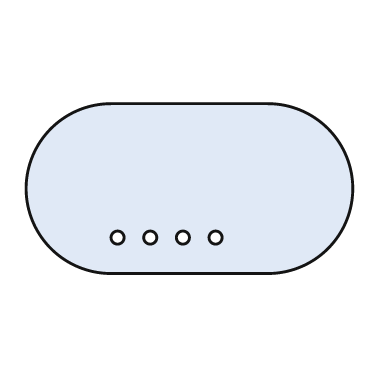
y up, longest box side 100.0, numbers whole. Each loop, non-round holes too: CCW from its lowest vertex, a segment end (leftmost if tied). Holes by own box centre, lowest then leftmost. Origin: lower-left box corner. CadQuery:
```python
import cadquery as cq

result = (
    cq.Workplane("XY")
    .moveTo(26.0, 0.0)
    .lineTo(74.0, 0.0)
    .threePointArc((100.0, 26.0), (74.0, 52.0))
    .lineTo(26.0, 52.0)
    .threePointArc((0.0, 26.0), (26.0, 0.0))
    .close()
    .moveTo(28.0, 11.0)
    .circle(2.0)
    .moveTo(38.0, 11.0)
    .circle(2.0)
    .moveTo(48.0, 11.0)
    .circle(2.0)
    .moveTo(58.0, 11.0)
    .circle(2.0)
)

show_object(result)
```